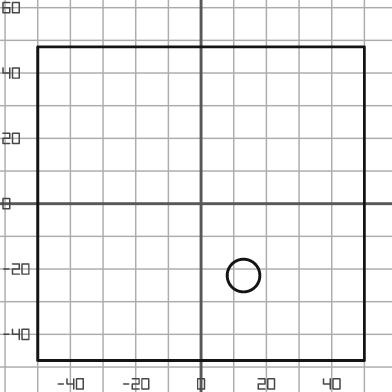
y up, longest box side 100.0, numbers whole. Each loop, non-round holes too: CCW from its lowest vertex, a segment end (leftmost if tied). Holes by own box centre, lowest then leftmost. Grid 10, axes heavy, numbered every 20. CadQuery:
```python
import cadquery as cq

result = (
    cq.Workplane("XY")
    .moveTo(-50.0, -48.0)
    .lineTo(50.0, -48.0)
    .lineTo(50.0, 48.0)
    .lineTo(-50.0, 48.0)
    .close()
    .moveTo(13.0, -22.0)
    .circle(5.0)
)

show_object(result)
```